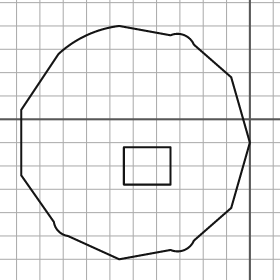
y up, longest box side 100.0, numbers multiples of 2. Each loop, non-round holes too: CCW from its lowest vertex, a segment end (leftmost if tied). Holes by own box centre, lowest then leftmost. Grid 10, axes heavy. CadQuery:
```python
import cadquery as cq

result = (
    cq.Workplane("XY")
    .moveTo(-56.0, -60.0)
    .lineTo(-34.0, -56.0)
    .threePointArc((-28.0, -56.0), (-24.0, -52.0))
    .lineTo(-8.0, -38.0)
    .lineTo(0.0, -10.0)
    .lineTo(-8.0, 18.0)
    .lineTo(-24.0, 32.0)
    .threePointArc((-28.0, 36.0), (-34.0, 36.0))
    .lineTo(-56.0, 40.0)
    .threePointArc((-70.0, 36.0), (-82.0, 28.0))
    .lineTo(-98.0, 4.0)
    .lineTo(-98.0, -24.0)
    .lineTo(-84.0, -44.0)
    .threePointArc((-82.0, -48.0), (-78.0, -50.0))
    .close()
    .moveTo(-54.0, -28.0)
    .lineTo(-34.0, -28.0)
    .lineTo(-34.0, -12.0)
    .lineTo(-54.0, -12.0)
    .close()
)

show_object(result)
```